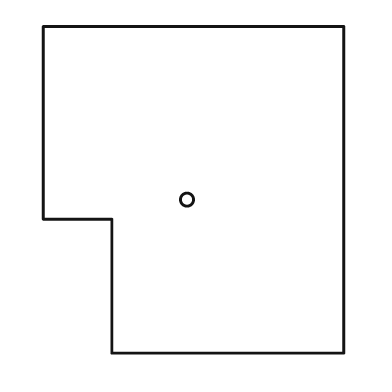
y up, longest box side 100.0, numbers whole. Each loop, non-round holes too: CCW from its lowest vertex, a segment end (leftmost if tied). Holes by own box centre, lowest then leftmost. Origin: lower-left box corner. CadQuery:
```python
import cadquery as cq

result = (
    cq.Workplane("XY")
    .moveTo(21.0, 0.0)
    .lineTo(92.0, 0.0)
    .lineTo(92.0, 100.0)
    .lineTo(0.0, 100.0)
    .lineTo(0.0, 41.0)
    .lineTo(21.0, 41.0)
    .close()
    .moveTo(44.0, 47.0)
    .circle(2.0)
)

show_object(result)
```